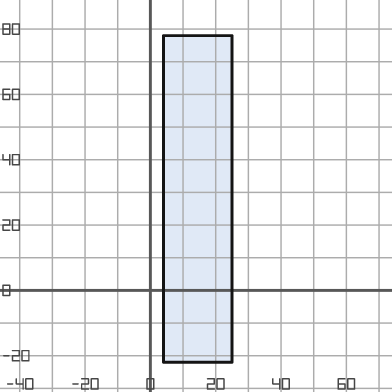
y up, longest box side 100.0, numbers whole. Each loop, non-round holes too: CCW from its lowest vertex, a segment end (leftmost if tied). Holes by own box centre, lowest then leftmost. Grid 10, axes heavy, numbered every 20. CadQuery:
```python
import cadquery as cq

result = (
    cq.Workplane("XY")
    .moveTo(4.0, -22.0)
    .lineTo(25.0, -22.0)
    .lineTo(25.0, 78.0)
    .lineTo(4.0, 78.0)
    .close()
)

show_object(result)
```